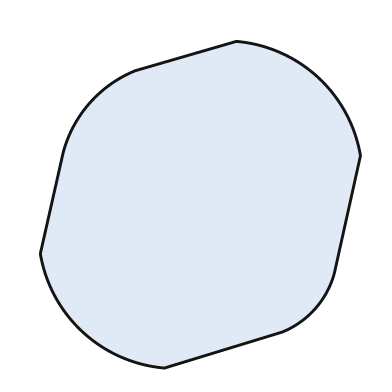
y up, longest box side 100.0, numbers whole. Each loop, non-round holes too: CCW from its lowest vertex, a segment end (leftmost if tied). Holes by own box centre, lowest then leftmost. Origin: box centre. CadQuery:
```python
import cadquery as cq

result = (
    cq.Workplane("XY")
    .moveTo(-11.0, -50.0)
    .lineTo(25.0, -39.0)
    .threePointArc((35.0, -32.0), (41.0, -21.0))
    .lineTo(49.0, 15.0)
    .threePointArc((36.0, 39.0), (11.0, 50.0))
    .lineTo(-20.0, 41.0)
    .threePointArc((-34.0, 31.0), (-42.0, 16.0))
    .lineTo(-49.0, -15.0)
    .threePointArc((-36.0, -39.0), (-11.0, -50.0))
    .close()
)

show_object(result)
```